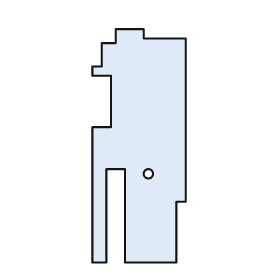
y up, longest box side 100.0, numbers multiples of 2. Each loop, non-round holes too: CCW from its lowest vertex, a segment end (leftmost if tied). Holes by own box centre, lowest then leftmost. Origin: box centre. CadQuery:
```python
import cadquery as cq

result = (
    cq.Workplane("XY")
    .moveTo(-20.0, -50.0)
    .lineTo(-14.0, -50.0)
    .lineTo(-14.0, -10.0)
    .lineTo(-6.0, -10.0)
    .lineTo(-6.0, -50.0)
    .lineTo(16.0, -50.0)
    .lineTo(16.0, -24.0)
    .lineTo(20.0, -24.0)
    .lineTo(20.0, 46.0)
    .lineTo(2.0, 46.0)
    .lineTo(2.0, 50.0)
    .lineTo(-10.0, 50.0)
    .lineTo(-10.0, 44.0)
    .lineTo(-16.0, 44.0)
    .lineTo(-16.0, 34.0)
    .lineTo(-20.0, 34.0)
    .lineTo(-20.0, 30.0)
    .lineTo(-12.0, 30.0)
    .lineTo(-12.0, 8.0)
    .lineTo(-20.0, 8.0)
    .close()
    .moveTo(4.0, -12.0)
    .circle(2.0)
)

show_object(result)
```